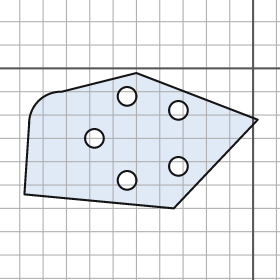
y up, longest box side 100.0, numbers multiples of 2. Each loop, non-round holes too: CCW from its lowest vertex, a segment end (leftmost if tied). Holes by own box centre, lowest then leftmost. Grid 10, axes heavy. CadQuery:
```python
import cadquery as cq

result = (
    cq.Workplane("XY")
    .moveTo(-34.0, -60.0)
    .lineTo(2.0, -22.0)
    .lineTo(-50.0, -2.0)
    .lineTo(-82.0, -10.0)
    .threePointArc((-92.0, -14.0), (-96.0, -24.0))
    .lineTo(-98.0, -54.0)
    .close()
    .moveTo(-54.0, -48.0)
    .circle(4.0)
    .moveTo(-32.0, -42.0)
    .circle(4.0)
    .moveTo(-68.0, -30.0)
    .circle(4.0)
    .moveTo(-32.0, -18.0)
    .circle(4.0)
    .moveTo(-54.0, -12.0)
    .circle(4.0)
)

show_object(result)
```